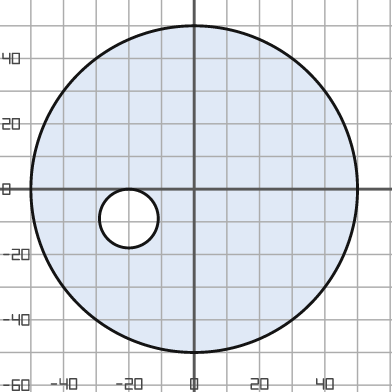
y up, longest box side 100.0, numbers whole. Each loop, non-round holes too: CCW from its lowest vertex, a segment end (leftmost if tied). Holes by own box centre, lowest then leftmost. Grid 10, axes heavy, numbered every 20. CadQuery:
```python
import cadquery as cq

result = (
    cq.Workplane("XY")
    .moveTo(0.0, 0.0)
    .circle(50.0)
    .moveTo(-20.0, -9.0)
    .circle(9.0)
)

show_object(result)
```